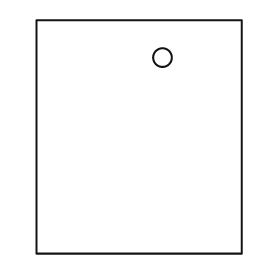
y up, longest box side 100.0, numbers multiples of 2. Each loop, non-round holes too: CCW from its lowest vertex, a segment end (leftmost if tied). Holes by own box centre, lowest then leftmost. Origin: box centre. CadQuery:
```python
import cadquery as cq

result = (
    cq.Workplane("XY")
    .moveTo(-44.0, -50.0)
    .lineTo(44.0, -50.0)
    .lineTo(44.0, 50.0)
    .lineTo(-44.0, 50.0)
    .close()
    .moveTo(10.0, 34.0)
    .circle(4.0)
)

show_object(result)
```